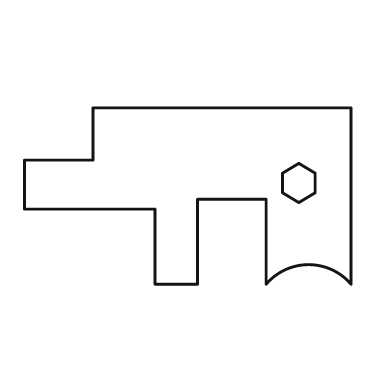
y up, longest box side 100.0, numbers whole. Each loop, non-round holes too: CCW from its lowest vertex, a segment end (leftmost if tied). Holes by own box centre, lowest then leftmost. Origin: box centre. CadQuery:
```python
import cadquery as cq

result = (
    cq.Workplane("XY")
    .moveTo(-10.0, -27.0)
    .lineTo(3.0, -27.0)
    .lineTo(3.0, -1.0)
    .lineTo(24.0, -1.0)
    .lineTo(24.0, -27.0)
    .threePointArc((37.0, -21.0), (50.0, -27.0))
    .lineTo(50.0, 27.0)
    .lineTo(-29.0, 27.0)
    .lineTo(-29.0, 11.0)
    .lineTo(-50.0, 11.0)
    .lineTo(-50.0, -4.0)
    .lineTo(-10.0, -4.0)
    .close()
    .moveTo(34.0, -2.0)
    .lineTo(39.0, 1.0)
    .lineTo(39.0, 7.0)
    .lineTo(34.0, 10.0)
    .lineTo(29.0, 7.0)
    .lineTo(29.0, 1.0)
    .close()
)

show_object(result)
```